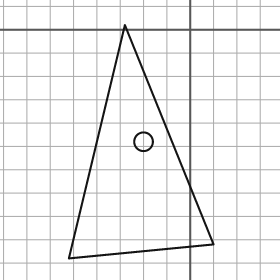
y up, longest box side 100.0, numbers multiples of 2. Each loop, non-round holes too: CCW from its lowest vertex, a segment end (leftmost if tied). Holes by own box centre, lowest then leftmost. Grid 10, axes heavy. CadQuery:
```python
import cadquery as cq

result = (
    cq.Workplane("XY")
    .moveTo(-52.0, -98.0)
    .lineTo(10.0, -92.0)
    .lineTo(-28.0, 2.0)
    .close()
    .moveTo(-20.0, -48.0)
    .circle(4.0)
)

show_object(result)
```